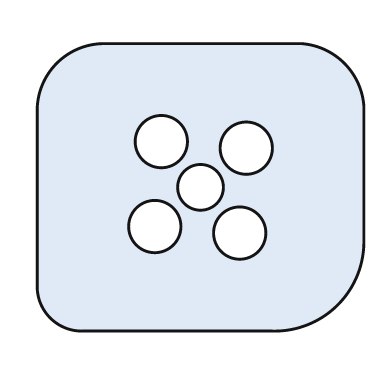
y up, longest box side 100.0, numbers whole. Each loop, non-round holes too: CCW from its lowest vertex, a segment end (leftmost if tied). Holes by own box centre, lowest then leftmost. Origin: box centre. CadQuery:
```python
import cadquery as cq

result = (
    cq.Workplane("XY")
    .moveTo(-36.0, -44.0)
    .lineTo(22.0, -44.0)
    .threePointArc((42.0, -36.0), (50.0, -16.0))
    .lineTo(50.0, 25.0)
    .threePointArc((44.0, 38.0), (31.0, 44.0))
    .lineTo(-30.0, 44.0)
    .threePointArc((-44.0, 38.0), (-50.0, 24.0))
    .lineTo(-50.0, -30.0)
    .threePointArc((-46.0, -40.0), (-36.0, -44.0))
    .close()
    .moveTo(12.0, -14.0)
    .circle(8.0)
    .moveTo(-14.0, -12.0)
    .circle(8.0)
    .moveTo(0.0, 0.0)
    .circle(7.0)
    .moveTo(14.0, 12.0)
    .circle(8.0)
    .moveTo(-12.0, 14.0)
    .circle(8.0)
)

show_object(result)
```